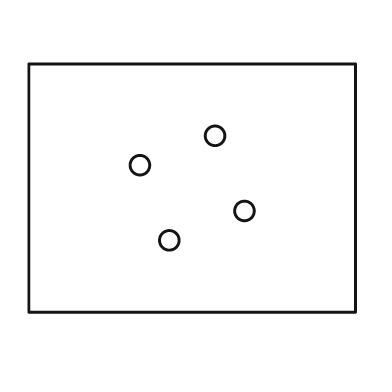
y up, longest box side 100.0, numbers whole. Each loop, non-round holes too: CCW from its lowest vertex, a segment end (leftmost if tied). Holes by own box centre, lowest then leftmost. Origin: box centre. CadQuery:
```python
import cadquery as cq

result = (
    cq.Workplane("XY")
    .moveTo(-50.0, -38.0)
    .lineTo(50.0, -38.0)
    .lineTo(50.0, 38.0)
    .lineTo(-50.0, 38.0)
    .close()
    .moveTo(-7.0, -16.0)
    .circle(3.0)
    .moveTo(16.0, -7.0)
    .circle(3.0)
    .moveTo(-16.0, 7.0)
    .circle(3.0)
    .moveTo(7.0, 16.0)
    .circle(3.0)
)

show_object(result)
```